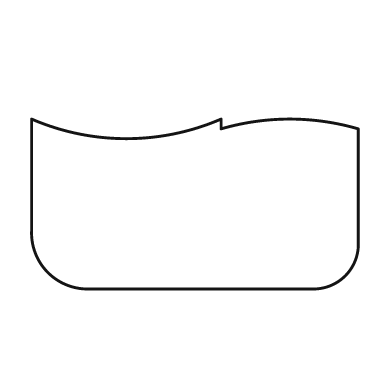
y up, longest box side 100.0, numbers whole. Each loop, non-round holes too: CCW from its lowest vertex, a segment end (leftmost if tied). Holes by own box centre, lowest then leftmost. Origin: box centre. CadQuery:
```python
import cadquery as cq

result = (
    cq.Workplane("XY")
    .moveTo(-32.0, -26.0)
    .lineTo(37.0, -26.0)
    .threePointArc((46.0, -22.0), (50.0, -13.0))
    .lineTo(50.0, 23.0)
    .threePointArc((29.0, 26.0), (8.0, 23.0))
    .lineTo(8.0, 26.0)
    .threePointArc((-21.0, 20.0), (-50.0, 26.0))
    .lineTo(-50.0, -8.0)
    .threePointArc((-45.0, -21.0), (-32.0, -26.0))
    .close()
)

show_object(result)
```